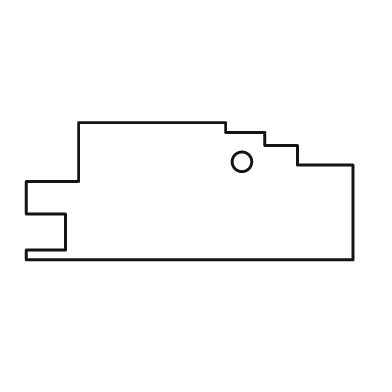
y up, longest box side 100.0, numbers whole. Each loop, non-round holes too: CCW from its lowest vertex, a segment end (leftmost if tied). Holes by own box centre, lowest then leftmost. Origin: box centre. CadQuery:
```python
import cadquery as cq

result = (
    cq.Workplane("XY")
    .moveTo(-50.0, -21.0)
    .lineTo(50.0, -21.0)
    .lineTo(50.0, 8.0)
    .lineTo(33.0, 8.0)
    .lineTo(33.0, 14.0)
    .lineTo(23.0, 14.0)
    .lineTo(23.0, 18.0)
    .lineTo(11.0, 18.0)
    .lineTo(11.0, 21.0)
    .lineTo(-34.0, 21.0)
    .lineTo(-34.0, 3.0)
    .lineTo(-50.0, 3.0)
    .lineTo(-50.0, -7.0)
    .lineTo(-38.0, -7.0)
    .lineTo(-38.0, -18.0)
    .lineTo(-50.0, -18.0)
    .close()
    .moveTo(16.0, 9.0)
    .circle(3.0)
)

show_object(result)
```